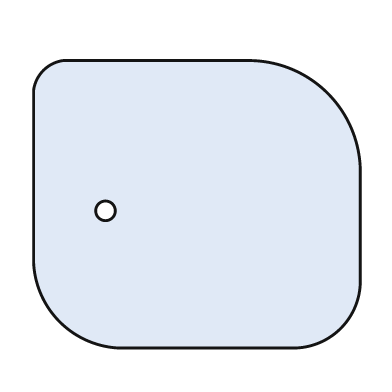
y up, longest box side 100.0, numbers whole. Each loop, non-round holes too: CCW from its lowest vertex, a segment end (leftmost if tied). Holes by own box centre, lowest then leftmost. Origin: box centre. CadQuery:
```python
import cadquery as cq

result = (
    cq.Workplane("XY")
    .moveTo(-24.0, -44.0)
    .lineTo(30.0, -44.0)
    .threePointArc((44.0, -38.0), (50.0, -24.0))
    .lineTo(50.0, 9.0)
    .threePointArc((40.0, 34.0), (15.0, 44.0))
    .lineTo(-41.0, 44.0)
    .threePointArc((-47.0, 41.0), (-50.0, 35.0))
    .lineTo(-50.0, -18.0)
    .threePointArc((-42.0, -36.0), (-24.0, -44.0))
    .close()
    .moveTo(-28.0, -2.0)
    .circle(3.0)
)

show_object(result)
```